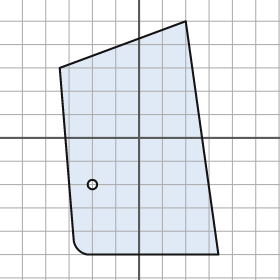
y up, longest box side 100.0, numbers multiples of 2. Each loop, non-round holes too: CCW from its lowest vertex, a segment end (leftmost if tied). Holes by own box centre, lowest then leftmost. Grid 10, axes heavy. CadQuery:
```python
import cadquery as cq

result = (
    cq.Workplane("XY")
    .moveTo(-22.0, -50.0)
    .lineTo(34.0, -50.0)
    .lineTo(20.0, 50.0)
    .lineTo(-34.0, 30.0)
    .lineTo(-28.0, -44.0)
    .threePointArc((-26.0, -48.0), (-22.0, -50.0))
    .close()
    .moveTo(-20.0, -20.0)
    .circle(2.0)
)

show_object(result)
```